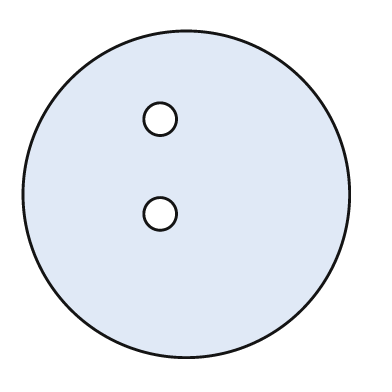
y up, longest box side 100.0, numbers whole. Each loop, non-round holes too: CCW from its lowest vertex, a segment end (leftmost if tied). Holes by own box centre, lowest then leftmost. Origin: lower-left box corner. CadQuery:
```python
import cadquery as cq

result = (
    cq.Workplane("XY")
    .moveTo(50.0, 50.0)
    .circle(50.0)
    .moveTo(42.0, 44.0)
    .circle(5.0)
    .moveTo(42.0, 73.0)
    .circle(5.0)
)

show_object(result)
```